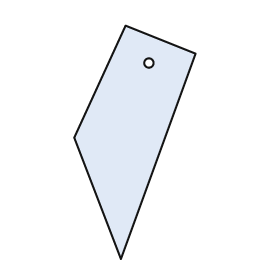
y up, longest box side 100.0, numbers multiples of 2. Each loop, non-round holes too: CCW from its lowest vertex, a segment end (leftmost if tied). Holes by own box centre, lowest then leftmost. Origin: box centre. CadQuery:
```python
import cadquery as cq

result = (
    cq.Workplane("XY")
    .moveTo(-6.0, -50.0)
    .lineTo(26.0, 38.0)
    .lineTo(-4.0, 50.0)
    .lineTo(-26.0, 2.0)
    .close()
    .moveTo(6.0, 34.0)
    .circle(2.0)
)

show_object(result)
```